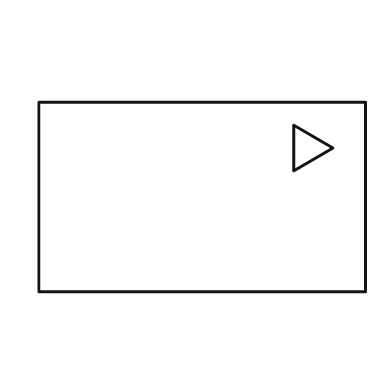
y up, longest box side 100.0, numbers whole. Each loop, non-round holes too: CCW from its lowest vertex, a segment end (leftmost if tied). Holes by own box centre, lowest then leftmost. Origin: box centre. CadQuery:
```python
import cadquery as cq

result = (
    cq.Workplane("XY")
    .moveTo(-50.0, -29.0)
    .lineTo(50.0, -29.0)
    .lineTo(50.0, 29.0)
    .lineTo(-50.0, 29.0)
    .close()
    .moveTo(28.0, 8.0)
    .lineTo(40.0, 15.0)
    .lineTo(28.0, 22.0)
    .close()
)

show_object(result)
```